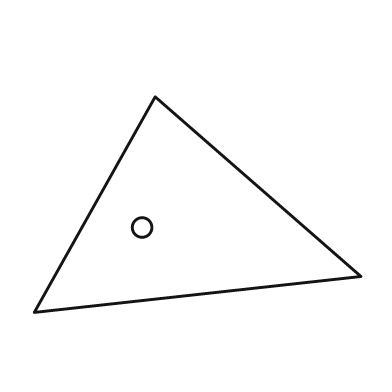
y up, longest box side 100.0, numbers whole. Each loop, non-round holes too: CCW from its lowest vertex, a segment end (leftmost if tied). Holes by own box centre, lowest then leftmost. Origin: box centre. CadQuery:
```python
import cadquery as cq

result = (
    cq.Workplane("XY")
    .moveTo(-50.0, -33.0)
    .lineTo(50.0, -22.0)
    .lineTo(-13.0, 33.0)
    .close()
    .moveTo(-17.0, -7.0)
    .circle(3.0)
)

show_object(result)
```